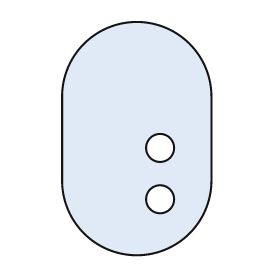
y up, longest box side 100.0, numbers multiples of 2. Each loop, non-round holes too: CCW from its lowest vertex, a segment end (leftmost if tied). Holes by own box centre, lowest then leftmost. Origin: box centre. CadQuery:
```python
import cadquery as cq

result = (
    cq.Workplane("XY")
    .moveTo(-32.0, -18.0)
    .threePointArc((0.0, -50.0), (32.0, -18.0))
    .lineTo(32.0, 18.0)
    .threePointArc((0.0, 50.0), (-32.0, 18.0))
    .close()
    .moveTo(10.0, -26.0)
    .circle(6.0)
    .moveTo(10.0, -4.0)
    .circle(6.0)
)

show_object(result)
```